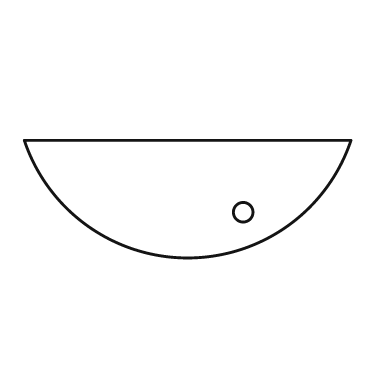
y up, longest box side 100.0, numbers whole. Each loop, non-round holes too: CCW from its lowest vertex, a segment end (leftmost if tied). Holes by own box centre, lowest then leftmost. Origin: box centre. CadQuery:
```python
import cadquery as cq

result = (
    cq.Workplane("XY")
    .moveTo(-50.0, 18.0)
    .threePointArc((0.0, -18.0), (50.0, 18.0))
    .close()
    .moveTo(17.0, -4.0)
    .circle(3.0)
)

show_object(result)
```